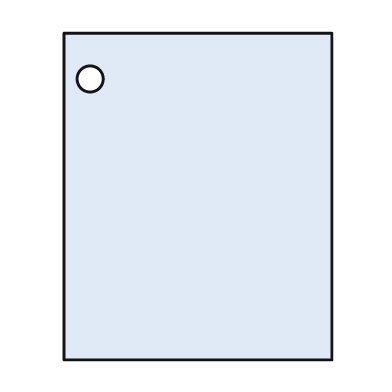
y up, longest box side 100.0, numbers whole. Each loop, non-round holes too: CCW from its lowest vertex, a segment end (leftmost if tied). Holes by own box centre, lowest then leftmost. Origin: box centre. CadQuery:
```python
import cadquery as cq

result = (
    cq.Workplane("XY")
    .moveTo(-41.0, -50.0)
    .lineTo(41.0, -50.0)
    .lineTo(41.0, 50.0)
    .lineTo(-41.0, 50.0)
    .close()
    .moveTo(-33.0, 36.0)
    .circle(4.0)
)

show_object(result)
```